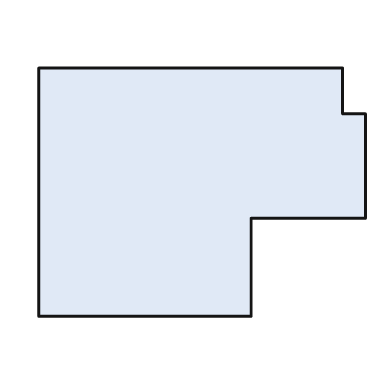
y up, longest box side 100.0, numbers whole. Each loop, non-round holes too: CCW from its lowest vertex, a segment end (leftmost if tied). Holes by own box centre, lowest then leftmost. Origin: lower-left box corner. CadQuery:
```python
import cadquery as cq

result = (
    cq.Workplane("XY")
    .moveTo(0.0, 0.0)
    .lineTo(65.0, 0.0)
    .lineTo(65.0, 30.0)
    .lineTo(100.0, 30.0)
    .lineTo(100.0, 62.0)
    .lineTo(93.0, 62.0)
    .lineTo(93.0, 76.0)
    .lineTo(0.0, 76.0)
    .close()
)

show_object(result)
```